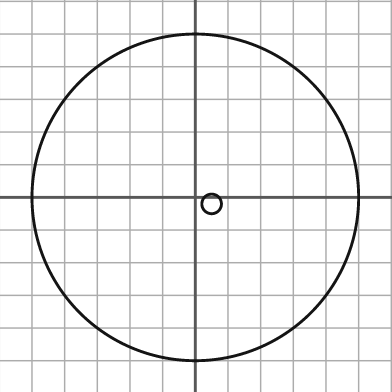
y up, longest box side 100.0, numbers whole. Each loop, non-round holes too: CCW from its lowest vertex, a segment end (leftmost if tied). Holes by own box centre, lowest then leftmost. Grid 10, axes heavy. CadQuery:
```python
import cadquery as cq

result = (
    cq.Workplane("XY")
    .moveTo(0.0, 0.0)
    .circle(50.0)
    .moveTo(5.0, -2.0)
    .circle(3.0)
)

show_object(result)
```